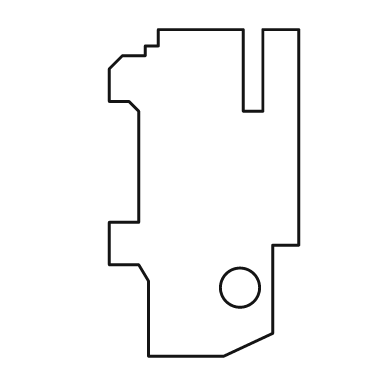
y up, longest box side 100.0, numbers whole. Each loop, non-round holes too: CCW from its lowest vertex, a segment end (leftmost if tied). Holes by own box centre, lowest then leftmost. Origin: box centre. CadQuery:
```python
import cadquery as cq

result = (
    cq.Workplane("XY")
    .moveTo(-17.0, -50.0)
    .lineTo(6.0, -50.0)
    .lineTo(21.0, -43.0)
    .lineTo(21.0, -16.0)
    .lineTo(29.0, -16.0)
    .lineTo(29.0, 50.0)
    .lineTo(18.0, 50.0)
    .lineTo(18.0, 25.0)
    .lineTo(12.0, 25.0)
    .lineTo(12.0, 50.0)
    .lineTo(-14.0, 50.0)
    .lineTo(-14.0, 45.0)
    .lineTo(-18.0, 45.0)
    .lineTo(-18.0, 42.0)
    .lineTo(-25.0, 42.0)
    .lineTo(-29.0, 38.0)
    .lineTo(-29.0, 28.0)
    .lineTo(-23.0, 28.0)
    .lineTo(-20.0, 25.0)
    .lineTo(-20.0, -9.0)
    .lineTo(-29.0, -9.0)
    .lineTo(-29.0, -22.0)
    .lineTo(-20.0, -22.0)
    .lineTo(-17.0, -27.0)
    .close()
    .moveTo(11.0, -29.0)
    .circle(6.0)
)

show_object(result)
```